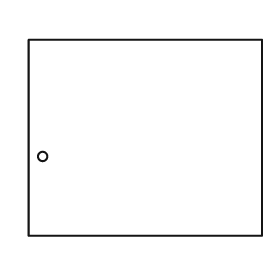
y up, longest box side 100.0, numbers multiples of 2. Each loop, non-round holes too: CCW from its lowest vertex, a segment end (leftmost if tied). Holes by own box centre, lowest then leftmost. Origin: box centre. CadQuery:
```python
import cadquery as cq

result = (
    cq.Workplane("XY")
    .moveTo(-50.0, -42.0)
    .lineTo(50.0, -42.0)
    .lineTo(50.0, 42.0)
    .lineTo(-50.0, 42.0)
    .close()
    .moveTo(-44.0, -8.0)
    .circle(2.0)
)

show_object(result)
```